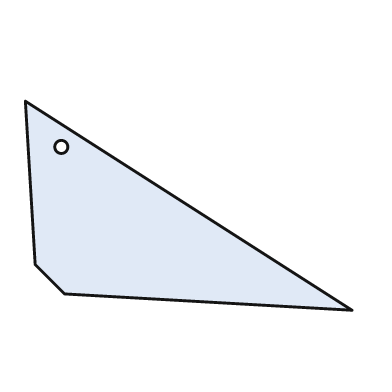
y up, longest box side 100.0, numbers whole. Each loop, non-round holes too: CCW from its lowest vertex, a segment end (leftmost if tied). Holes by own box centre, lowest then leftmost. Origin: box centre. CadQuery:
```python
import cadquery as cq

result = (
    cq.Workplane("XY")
    .moveTo(50.0, -32.0)
    .lineTo(-50.0, 32.0)
    .lineTo(-47.0, -18.0)
    .lineTo(-38.0, -27.0)
    .close()
    .moveTo(-39.0, 18.0)
    .circle(2.0)
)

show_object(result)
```